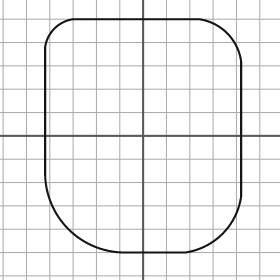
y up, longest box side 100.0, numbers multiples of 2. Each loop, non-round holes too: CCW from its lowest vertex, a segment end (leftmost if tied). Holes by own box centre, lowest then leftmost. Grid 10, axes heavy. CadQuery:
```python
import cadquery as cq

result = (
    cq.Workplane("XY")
    .moveTo(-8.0, -50.0)
    .lineTo(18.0, -50.0)
    .threePointArc((34.0, -42.0), (42.0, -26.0))
    .lineTo(42.0, 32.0)
    .threePointArc((36.0, 44.0), (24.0, 50.0))
    .lineTo(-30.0, 50.0)
    .threePointArc((-38.0, 46.0), (-42.0, 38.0))
    .lineTo(-42.0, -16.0)
    .threePointArc((-32.0, -40.0), (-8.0, -50.0))
    .close()
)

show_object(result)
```